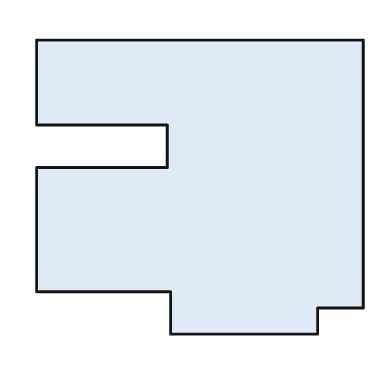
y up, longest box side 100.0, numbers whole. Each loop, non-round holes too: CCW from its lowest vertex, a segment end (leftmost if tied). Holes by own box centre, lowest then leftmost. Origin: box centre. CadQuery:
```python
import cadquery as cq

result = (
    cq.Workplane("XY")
    .moveTo(-9.0, -45.0)
    .lineTo(36.0, -45.0)
    .lineTo(36.0, -37.0)
    .lineTo(50.0, -37.0)
    .lineTo(50.0, 45.0)
    .lineTo(-50.0, 45.0)
    .lineTo(-50.0, 19.0)
    .lineTo(-10.0, 19.0)
    .lineTo(-10.0, 6.0)
    .lineTo(-50.0, 6.0)
    .lineTo(-50.0, -32.0)
    .lineTo(-9.0, -32.0)
    .close()
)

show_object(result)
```